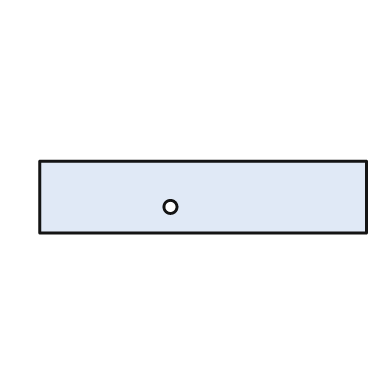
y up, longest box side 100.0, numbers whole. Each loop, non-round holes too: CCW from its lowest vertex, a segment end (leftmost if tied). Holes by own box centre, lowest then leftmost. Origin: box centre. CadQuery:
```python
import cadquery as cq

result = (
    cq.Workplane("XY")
    .moveTo(-50.0, -11.0)
    .lineTo(50.0, -11.0)
    .lineTo(50.0, 11.0)
    .lineTo(-50.0, 11.0)
    .close()
    .moveTo(-10.0, -3.0)
    .circle(2.0)
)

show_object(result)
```